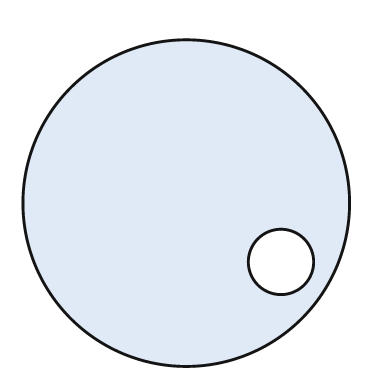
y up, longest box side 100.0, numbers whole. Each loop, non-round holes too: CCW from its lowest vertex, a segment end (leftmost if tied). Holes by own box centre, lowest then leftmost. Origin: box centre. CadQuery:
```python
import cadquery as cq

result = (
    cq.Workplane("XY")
    .moveTo(0.0, 0.0)
    .circle(50.0)
    .moveTo(29.0, -18.0)
    .circle(10.0)
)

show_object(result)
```